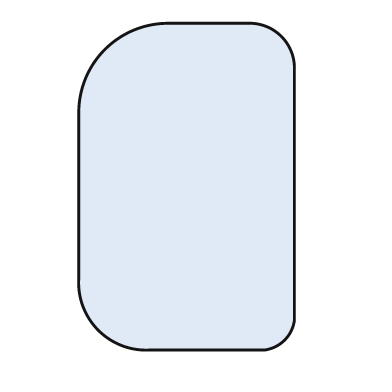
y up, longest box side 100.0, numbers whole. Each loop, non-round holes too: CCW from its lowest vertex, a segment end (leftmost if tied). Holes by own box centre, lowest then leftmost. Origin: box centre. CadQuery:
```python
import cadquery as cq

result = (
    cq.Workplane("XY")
    .moveTo(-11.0, -50.0)
    .lineTo(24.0, -50.0)
    .threePointArc((30.0, -47.0), (33.0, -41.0))
    .lineTo(33.0, 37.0)
    .threePointArc((29.0, 46.0), (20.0, 50.0))
    .lineTo(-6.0, 50.0)
    .threePointArc((-25.0, 42.0), (-33.0, 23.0))
    .lineTo(-33.0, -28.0)
    .threePointArc((-27.0, -44.0), (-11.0, -50.0))
    .close()
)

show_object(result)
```